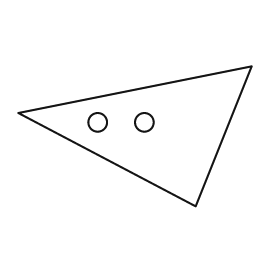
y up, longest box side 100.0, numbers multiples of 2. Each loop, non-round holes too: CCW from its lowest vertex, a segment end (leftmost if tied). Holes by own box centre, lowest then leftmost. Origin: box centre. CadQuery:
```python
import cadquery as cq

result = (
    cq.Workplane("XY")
    .moveTo(26.0, -30.0)
    .lineTo(50.0, 30.0)
    .lineTo(-50.0, 10.0)
    .close()
    .moveTo(-16.0, 6.0)
    .circle(4.0)
    .moveTo(4.0, 6.0)
    .circle(4.0)
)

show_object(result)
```